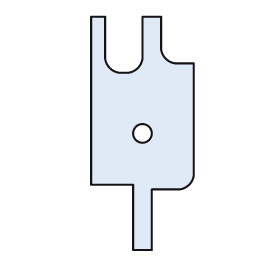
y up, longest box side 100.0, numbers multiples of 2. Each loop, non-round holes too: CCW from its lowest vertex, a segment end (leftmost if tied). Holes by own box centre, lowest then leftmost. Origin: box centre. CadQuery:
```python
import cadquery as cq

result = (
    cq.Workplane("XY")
    .moveTo(-4.0, -50.0)
    .lineTo(4.0, -50.0)
    .lineTo(4.0, -24.0)
    .lineTo(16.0, -24.0)
    .threePointArc((20.0, -22.0), (22.0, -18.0))
    .lineTo(22.0, 30.0)
    .lineTo(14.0, 30.0)
    .threePointArc((10.0, 32.0), (8.0, 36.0))
    .lineTo(8.0, 50.0)
    .lineTo(0.0, 50.0)
    .lineTo(0.0, 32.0)
    .threePointArc((-2.0, 28.0), (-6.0, 26.0))
    .lineTo(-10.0, 26.0)
    .threePointArc((-14.0, 28.0), (-16.0, 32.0))
    .lineTo(-16.0, 50.0)
    .lineTo(-22.0, 50.0)
    .lineTo(-22.0, -22.0)
    .lineTo(-4.0, -22.0)
    .close()
    .moveTo(0.0, 0.0)
    .circle(4.0)
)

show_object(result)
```